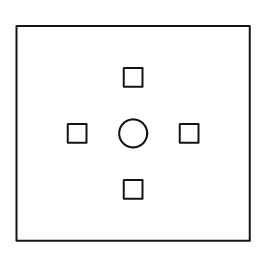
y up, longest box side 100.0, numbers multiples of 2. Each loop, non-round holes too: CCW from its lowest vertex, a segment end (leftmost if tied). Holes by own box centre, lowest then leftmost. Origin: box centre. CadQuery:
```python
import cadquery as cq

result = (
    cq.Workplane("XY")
    .moveTo(-50.0, -46.0)
    .lineTo(50.0, -46.0)
    .lineTo(50.0, 46.0)
    .lineTo(-50.0, 46.0)
    .close()
    .moveTo(-4.0, -28.0)
    .lineTo(4.0, -28.0)
    .lineTo(4.0, -20.0)
    .lineTo(-4.0, -20.0)
    .close()
    .moveTo(-28.0, -4.0)
    .lineTo(-20.0, -4.0)
    .lineTo(-20.0, 4.0)
    .lineTo(-28.0, 4.0)
    .close()
    .moveTo(0.0, 0.0)
    .circle(6.0)
    .moveTo(20.0, -4.0)
    .lineTo(28.0, -4.0)
    .lineTo(28.0, 4.0)
    .lineTo(20.0, 4.0)
    .close()
    .moveTo(-4.0, 20.0)
    .lineTo(4.0, 20.0)
    .lineTo(4.0, 28.0)
    .lineTo(-4.0, 28.0)
    .close()
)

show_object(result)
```